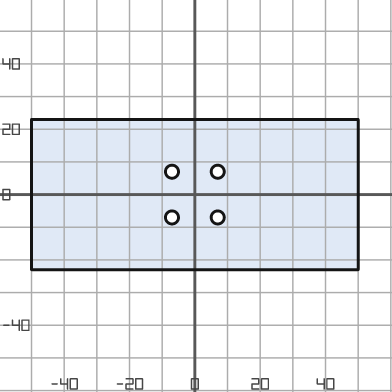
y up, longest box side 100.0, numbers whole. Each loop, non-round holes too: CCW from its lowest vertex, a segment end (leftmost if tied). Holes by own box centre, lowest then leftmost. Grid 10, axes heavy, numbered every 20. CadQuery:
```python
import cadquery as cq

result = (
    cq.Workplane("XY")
    .moveTo(-50.0, -23.0)
    .lineTo(50.0, -23.0)
    .lineTo(50.0, 23.0)
    .lineTo(-50.0, 23.0)
    .close()
    .moveTo(-7.0, -7.0)
    .circle(2.0)
    .moveTo(7.0, -7.0)
    .circle(2.0)
    .moveTo(-7.0, 7.0)
    .circle(2.0)
    .moveTo(7.0, 7.0)
    .circle(2.0)
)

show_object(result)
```